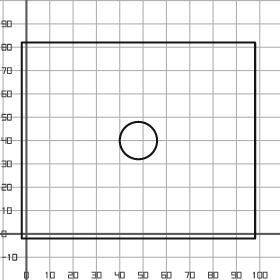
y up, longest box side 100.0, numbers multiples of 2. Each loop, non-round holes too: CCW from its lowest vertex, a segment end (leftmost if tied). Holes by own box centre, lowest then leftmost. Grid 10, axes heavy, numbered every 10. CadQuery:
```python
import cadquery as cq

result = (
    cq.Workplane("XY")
    .moveTo(-2.0, -2.0)
    .lineTo(98.0, -2.0)
    .lineTo(98.0, 82.0)
    .lineTo(-2.0, 82.0)
    .close()
    .moveTo(48.0, 40.0)
    .circle(8.0)
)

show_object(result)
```